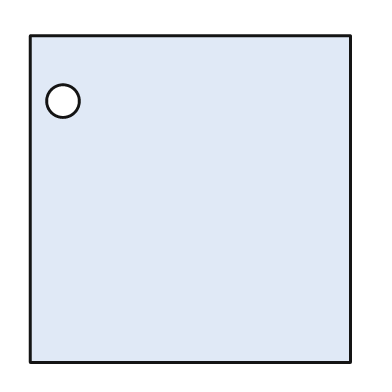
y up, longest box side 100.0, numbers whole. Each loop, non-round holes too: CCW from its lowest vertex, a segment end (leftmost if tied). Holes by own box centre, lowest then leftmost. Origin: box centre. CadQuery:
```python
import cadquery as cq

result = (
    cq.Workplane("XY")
    .moveTo(-49.0, -50.0)
    .lineTo(49.0, -50.0)
    .lineTo(49.0, 50.0)
    .lineTo(-49.0, 50.0)
    .close()
    .moveTo(-39.0, 30.0)
    .circle(5.0)
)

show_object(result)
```